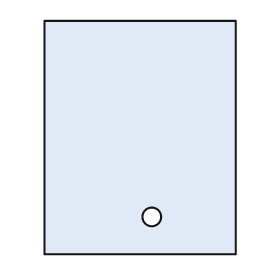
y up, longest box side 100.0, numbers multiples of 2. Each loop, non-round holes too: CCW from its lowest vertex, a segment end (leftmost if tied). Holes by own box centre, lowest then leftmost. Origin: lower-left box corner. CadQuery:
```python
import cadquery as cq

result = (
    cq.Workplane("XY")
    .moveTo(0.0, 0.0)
    .lineTo(82.0, 0.0)
    .lineTo(82.0, 100.0)
    .lineTo(0.0, 100.0)
    .close()
    .moveTo(46.0, 16.0)
    .circle(4.0)
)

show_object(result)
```